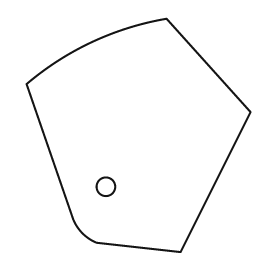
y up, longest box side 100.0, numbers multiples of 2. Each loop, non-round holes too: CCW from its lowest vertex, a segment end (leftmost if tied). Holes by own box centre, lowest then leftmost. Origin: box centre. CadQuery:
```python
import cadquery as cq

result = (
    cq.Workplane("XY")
    .moveTo(18.0, -50.0)
    .lineTo(48.0, 10.0)
    .lineTo(12.0, 50.0)
    .threePointArc((-20.0, 40.0), (-48.0, 22.0))
    .lineTo(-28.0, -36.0)
    .threePointArc((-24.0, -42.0), (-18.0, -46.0))
    .close()
    .moveTo(-14.0, -22.0)
    .circle(4.0)
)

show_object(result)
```